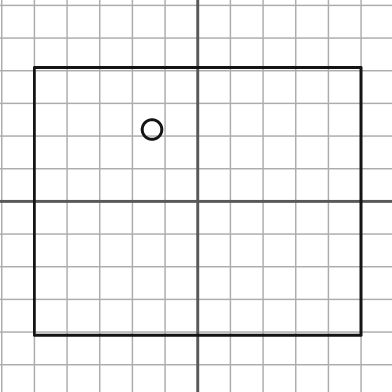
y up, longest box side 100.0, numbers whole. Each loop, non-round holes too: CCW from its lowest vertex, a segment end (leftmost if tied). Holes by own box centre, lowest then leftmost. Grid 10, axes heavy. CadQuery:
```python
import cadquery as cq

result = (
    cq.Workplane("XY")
    .moveTo(-50.0, -41.0)
    .lineTo(50.0, -41.0)
    .lineTo(50.0, 41.0)
    .lineTo(-50.0, 41.0)
    .close()
    .moveTo(-14.0, 22.0)
    .circle(3.0)
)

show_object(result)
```